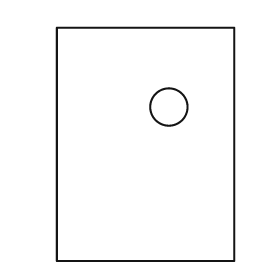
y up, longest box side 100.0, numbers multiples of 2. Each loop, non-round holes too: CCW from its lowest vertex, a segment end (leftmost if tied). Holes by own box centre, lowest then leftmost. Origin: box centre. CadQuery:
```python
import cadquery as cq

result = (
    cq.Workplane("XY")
    .moveTo(-38.0, -50.0)
    .lineTo(38.0, -50.0)
    .lineTo(38.0, 50.0)
    .lineTo(-38.0, 50.0)
    .close()
    .moveTo(10.0, 16.0)
    .circle(8.0)
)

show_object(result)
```